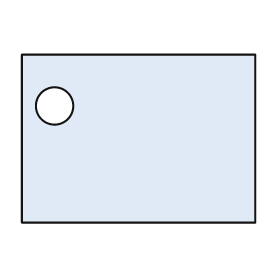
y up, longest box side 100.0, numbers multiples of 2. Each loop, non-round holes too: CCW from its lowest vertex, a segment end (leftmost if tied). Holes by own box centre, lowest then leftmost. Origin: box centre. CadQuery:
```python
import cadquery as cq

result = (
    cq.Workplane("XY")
    .moveTo(-50.0, -36.0)
    .lineTo(50.0, -36.0)
    .lineTo(50.0, 36.0)
    .lineTo(-50.0, 36.0)
    .close()
    .moveTo(-36.0, 14.0)
    .circle(8.0)
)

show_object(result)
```